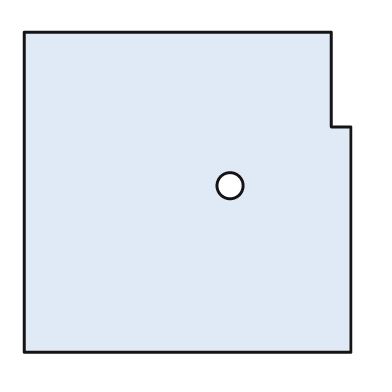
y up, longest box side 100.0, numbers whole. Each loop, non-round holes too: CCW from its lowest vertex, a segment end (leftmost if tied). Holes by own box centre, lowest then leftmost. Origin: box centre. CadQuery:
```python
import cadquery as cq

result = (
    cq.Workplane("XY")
    .moveTo(-50.0, -49.0)
    .lineTo(50.0, -49.0)
    .lineTo(50.0, 20.0)
    .lineTo(44.0, 20.0)
    .lineTo(44.0, 49.0)
    .lineTo(-50.0, 49.0)
    .close()
    .moveTo(13.0, 2.0)
    .circle(4.0)
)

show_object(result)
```